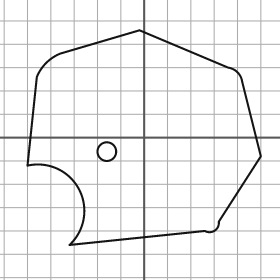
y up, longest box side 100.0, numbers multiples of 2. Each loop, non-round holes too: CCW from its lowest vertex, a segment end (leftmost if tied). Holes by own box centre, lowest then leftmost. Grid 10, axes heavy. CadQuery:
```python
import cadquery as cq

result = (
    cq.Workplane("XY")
    .moveTo(-32.0, -46.0)
    .lineTo(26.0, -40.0)
    .threePointArc((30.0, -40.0), (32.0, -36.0))
    .lineTo(50.0, -8.0)
    .lineTo(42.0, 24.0)
    .threePointArc((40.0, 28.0), (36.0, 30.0))
    .lineTo(-2.0, 46.0)
    .lineTo(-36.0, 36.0)
    .threePointArc((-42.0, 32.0), (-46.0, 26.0))
    .lineTo(-50.0, -12.0)
    .threePointArc((-28.0, -22.0), (-32.0, -46.0))
    .close()
    .moveTo(-16.0, -6.0)
    .circle(4.0)
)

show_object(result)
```